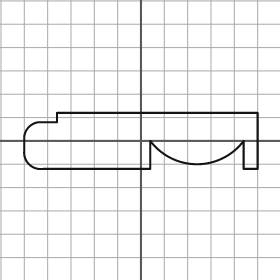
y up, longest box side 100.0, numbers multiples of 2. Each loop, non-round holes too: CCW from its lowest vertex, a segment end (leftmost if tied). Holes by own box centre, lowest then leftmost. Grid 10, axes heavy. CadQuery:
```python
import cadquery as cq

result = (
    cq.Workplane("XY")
    .moveTo(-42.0, -12.0)
    .lineTo(4.0, -12.0)
    .lineTo(4.0, 0.0)
    .threePointArc((24.0, -10.0), (44.0, 0.0))
    .lineTo(44.0, -12.0)
    .lineTo(50.0, -12.0)
    .lineTo(50.0, 12.0)
    .lineTo(-36.0, 12.0)
    .lineTo(-36.0, 8.0)
    .lineTo(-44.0, 8.0)
    .threePointArc((-48.0, 6.0), (-50.0, 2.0))
    .lineTo(-50.0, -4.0)
    .threePointArc((-48.0, -10.0), (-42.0, -12.0))
    .close()
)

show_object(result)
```